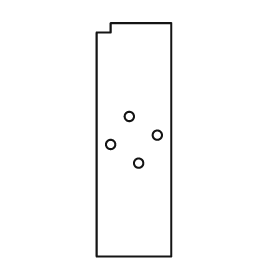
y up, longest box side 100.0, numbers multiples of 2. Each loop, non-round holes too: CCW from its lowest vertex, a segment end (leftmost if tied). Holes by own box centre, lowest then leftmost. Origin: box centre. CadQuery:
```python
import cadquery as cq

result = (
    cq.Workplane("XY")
    .moveTo(-16.0, -50.0)
    .lineTo(16.0, -50.0)
    .lineTo(16.0, 50.0)
    .lineTo(-10.0, 50.0)
    .lineTo(-10.0, 46.0)
    .lineTo(-16.0, 46.0)
    .close()
    .moveTo(2.0, -10.0)
    .circle(2.0)
    .moveTo(-10.0, -2.0)
    .circle(2.0)
    .moveTo(10.0, 2.0)
    .circle(2.0)
    .moveTo(-2.0, 10.0)
    .circle(2.0)
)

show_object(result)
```